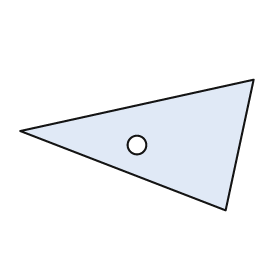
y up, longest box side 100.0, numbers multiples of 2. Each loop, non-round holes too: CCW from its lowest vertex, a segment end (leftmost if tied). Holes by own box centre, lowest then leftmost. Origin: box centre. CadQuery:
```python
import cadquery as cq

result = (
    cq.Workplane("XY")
    .moveTo(38.0, -28.0)
    .lineTo(50.0, 28.0)
    .lineTo(-50.0, 6.0)
    .close()
    .moveTo(0.0, 0.0)
    .circle(4.0)
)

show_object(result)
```